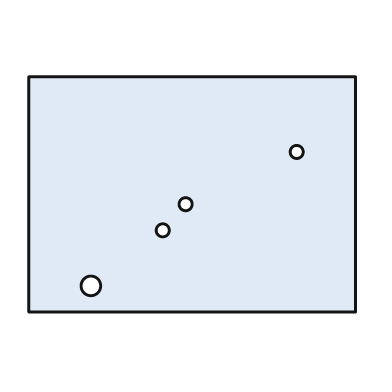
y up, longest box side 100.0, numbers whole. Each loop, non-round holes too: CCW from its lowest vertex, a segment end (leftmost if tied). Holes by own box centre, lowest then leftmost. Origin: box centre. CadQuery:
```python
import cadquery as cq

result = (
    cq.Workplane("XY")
    .moveTo(-50.0, -36.0)
    .lineTo(50.0, -36.0)
    .lineTo(50.0, 36.0)
    .lineTo(-50.0, 36.0)
    .close()
    .moveTo(-31.0, -28.0)
    .circle(3.0)
    .moveTo(-9.0, -11.0)
    .circle(2.0)
    .moveTo(-2.0, -3.0)
    .circle(2.0)
    .moveTo(32.0, 13.0)
    .circle(2.0)
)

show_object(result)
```